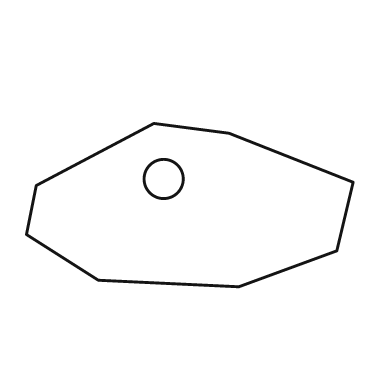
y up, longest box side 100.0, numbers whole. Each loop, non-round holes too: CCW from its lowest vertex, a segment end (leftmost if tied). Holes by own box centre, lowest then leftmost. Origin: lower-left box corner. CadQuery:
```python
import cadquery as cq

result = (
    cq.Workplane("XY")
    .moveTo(65.0, 0.0)
    .lineTo(95.0, 11.0)
    .lineTo(100.0, 32.0)
    .lineTo(62.0, 47.0)
    .lineTo(39.0, 50.0)
    .lineTo(3.0, 31.0)
    .lineTo(0.0, 16.0)
    .lineTo(22.0, 2.0)
    .close()
    .moveTo(42.0, 33.0)
    .circle(6.0)
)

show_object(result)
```